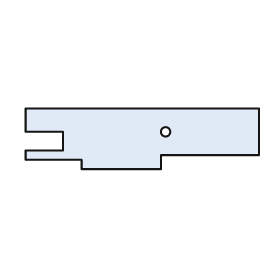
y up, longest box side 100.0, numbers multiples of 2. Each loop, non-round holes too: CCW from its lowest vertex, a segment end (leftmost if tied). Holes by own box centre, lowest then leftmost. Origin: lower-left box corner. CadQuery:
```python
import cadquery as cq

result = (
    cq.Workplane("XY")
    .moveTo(24.0, 0.0)
    .lineTo(58.0, 0.0)
    .lineTo(58.0, 6.0)
    .lineTo(100.0, 6.0)
    .lineTo(100.0, 26.0)
    .lineTo(0.0, 26.0)
    .lineTo(0.0, 16.0)
    .lineTo(16.0, 16.0)
    .lineTo(16.0, 8.0)
    .lineTo(0.0, 8.0)
    .lineTo(0.0, 4.0)
    .lineTo(24.0, 4.0)
    .close()
    .moveTo(60.0, 16.0)
    .circle(2.0)
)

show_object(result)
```